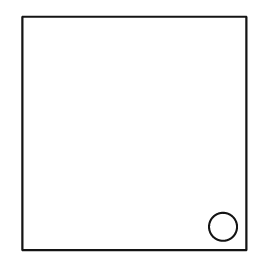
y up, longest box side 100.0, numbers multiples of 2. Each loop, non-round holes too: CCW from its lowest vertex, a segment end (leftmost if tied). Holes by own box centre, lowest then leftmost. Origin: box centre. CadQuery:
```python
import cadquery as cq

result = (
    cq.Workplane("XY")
    .moveTo(-48.0, -50.0)
    .lineTo(48.0, -50.0)
    .lineTo(48.0, 50.0)
    .lineTo(-48.0, 50.0)
    .close()
    .moveTo(38.0, -40.0)
    .circle(6.0)
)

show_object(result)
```